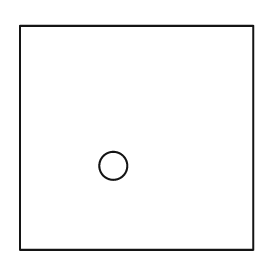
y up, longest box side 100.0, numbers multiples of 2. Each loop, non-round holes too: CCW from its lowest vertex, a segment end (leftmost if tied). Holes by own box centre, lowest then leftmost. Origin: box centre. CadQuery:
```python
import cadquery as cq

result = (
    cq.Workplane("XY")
    .moveTo(-50.0, -48.0)
    .lineTo(50.0, -48.0)
    .lineTo(50.0, 48.0)
    .lineTo(-50.0, 48.0)
    .close()
    .moveTo(-10.0, -12.0)
    .circle(6.0)
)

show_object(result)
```